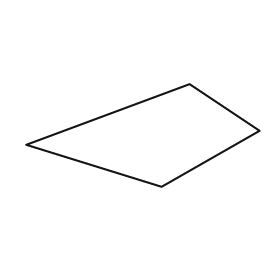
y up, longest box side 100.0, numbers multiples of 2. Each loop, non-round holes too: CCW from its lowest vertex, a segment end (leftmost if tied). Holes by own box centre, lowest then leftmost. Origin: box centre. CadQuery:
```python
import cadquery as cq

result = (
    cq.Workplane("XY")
    .moveTo(8.0, -22.0)
    .lineTo(50.0, 2.0)
    .lineTo(20.0, 22.0)
    .lineTo(-50.0, -4.0)
    .close()
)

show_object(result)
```